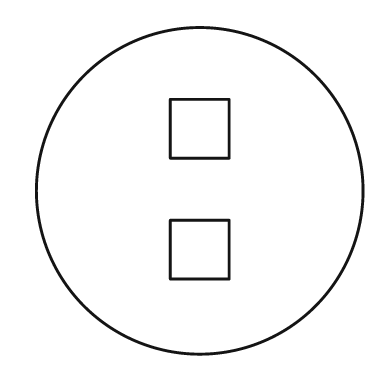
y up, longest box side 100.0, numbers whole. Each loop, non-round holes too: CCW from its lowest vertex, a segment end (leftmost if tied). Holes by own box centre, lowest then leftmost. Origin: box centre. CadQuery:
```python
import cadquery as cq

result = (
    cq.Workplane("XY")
    .moveTo(0.0, 0.0)
    .circle(50.0)
    .moveTo(-9.0, -27.0)
    .lineTo(9.0, -27.0)
    .lineTo(9.0, -9.0)
    .lineTo(-9.0, -9.0)
    .close()
    .moveTo(-9.0, 10.0)
    .lineTo(9.0, 10.0)
    .lineTo(9.0, 28.0)
    .lineTo(-9.0, 28.0)
    .close()
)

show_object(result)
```